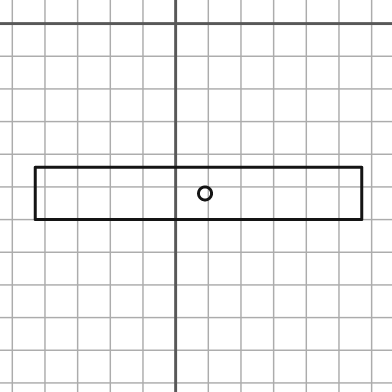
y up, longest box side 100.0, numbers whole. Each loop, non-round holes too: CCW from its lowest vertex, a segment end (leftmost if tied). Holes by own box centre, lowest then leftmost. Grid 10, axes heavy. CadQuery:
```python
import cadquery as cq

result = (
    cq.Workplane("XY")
    .moveTo(-43.0, -60.0)
    .lineTo(57.0, -60.0)
    .lineTo(57.0, -44.0)
    .lineTo(-43.0, -44.0)
    .close()
    .moveTo(9.0, -52.0)
    .circle(2.0)
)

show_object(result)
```